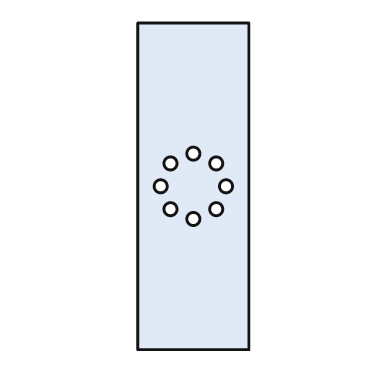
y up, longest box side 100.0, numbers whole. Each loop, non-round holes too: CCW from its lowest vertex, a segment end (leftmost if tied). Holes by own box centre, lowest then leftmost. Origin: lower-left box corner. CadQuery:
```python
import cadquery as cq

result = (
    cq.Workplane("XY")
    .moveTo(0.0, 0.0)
    .lineTo(34.0, 0.0)
    .lineTo(34.0, 100.0)
    .lineTo(0.0, 100.0)
    .close()
    .moveTo(17.0, 40.0)
    .circle(2.0)
    .moveTo(10.0, 43.0)
    .circle(2.0)
    .moveTo(24.0, 43.0)
    .circle(2.0)
    .moveTo(7.0, 50.0)
    .circle(2.0)
    .moveTo(27.0, 50.0)
    .circle(2.0)
    .moveTo(10.0, 57.0)
    .circle(2.0)
    .moveTo(24.0, 57.0)
    .circle(2.0)
    .moveTo(17.0, 60.0)
    .circle(2.0)
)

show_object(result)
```